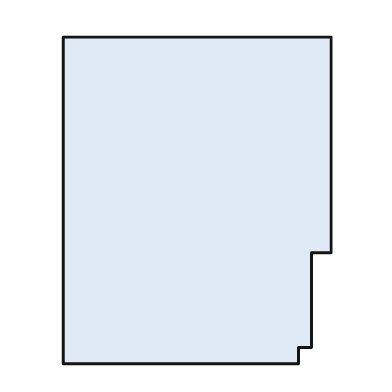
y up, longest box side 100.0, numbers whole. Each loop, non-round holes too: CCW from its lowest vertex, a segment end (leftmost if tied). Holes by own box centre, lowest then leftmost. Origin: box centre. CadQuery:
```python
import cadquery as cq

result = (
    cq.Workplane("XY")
    .moveTo(-41.0, -50.0)
    .lineTo(31.0, -50.0)
    .lineTo(31.0, -45.0)
    .lineTo(35.0, -45.0)
    .lineTo(35.0, -16.0)
    .lineTo(41.0, -16.0)
    .lineTo(41.0, 50.0)
    .lineTo(-41.0, 50.0)
    .close()
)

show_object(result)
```